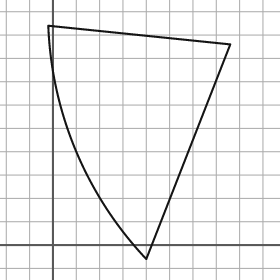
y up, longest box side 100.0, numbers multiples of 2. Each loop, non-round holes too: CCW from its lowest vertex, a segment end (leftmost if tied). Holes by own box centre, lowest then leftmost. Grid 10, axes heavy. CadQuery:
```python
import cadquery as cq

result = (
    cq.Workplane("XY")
    .moveTo(40.0, -6.0)
    .lineTo(76.0, 86.0)
    .lineTo(-2.0, 94.0)
    .threePointArc((10.0, 40.0), (40.0, -6.0))
    .close()
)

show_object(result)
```